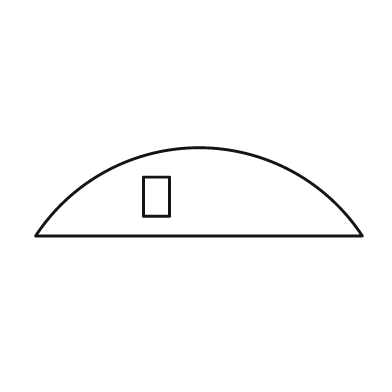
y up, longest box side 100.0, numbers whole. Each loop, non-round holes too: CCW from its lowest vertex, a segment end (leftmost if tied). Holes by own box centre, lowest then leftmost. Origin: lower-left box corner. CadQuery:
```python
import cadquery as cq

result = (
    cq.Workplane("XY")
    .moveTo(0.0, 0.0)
    .lineTo(100.0, 0.0)
    .threePointArc((50.0, 27.0), (0.0, 0.0))
    .close()
    .moveTo(33.0, 6.0)
    .lineTo(41.0, 6.0)
    .lineTo(41.0, 18.0)
    .lineTo(33.0, 18.0)
    .close()
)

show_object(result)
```